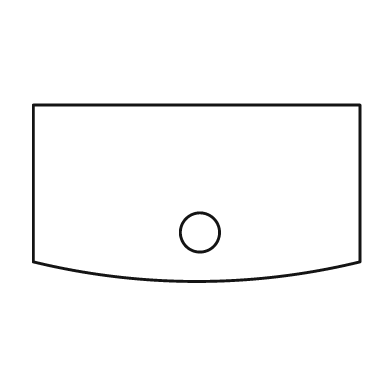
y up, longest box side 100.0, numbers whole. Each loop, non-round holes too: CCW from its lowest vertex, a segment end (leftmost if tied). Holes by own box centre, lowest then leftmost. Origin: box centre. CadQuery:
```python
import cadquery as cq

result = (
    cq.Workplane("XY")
    .moveTo(-50.0, -21.0)
    .threePointArc((0.0, -27.0), (50.0, -21.0))
    .lineTo(50.0, 27.0)
    .lineTo(-50.0, 27.0)
    .close()
    .moveTo(1.0, -12.0)
    .circle(6.0)
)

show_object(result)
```